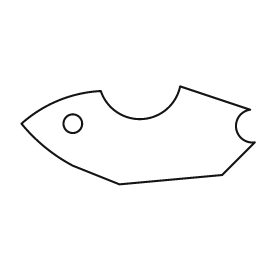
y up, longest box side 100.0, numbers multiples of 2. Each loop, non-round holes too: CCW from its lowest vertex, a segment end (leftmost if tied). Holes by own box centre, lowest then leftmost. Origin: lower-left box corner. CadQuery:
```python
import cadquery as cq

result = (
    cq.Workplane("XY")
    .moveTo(42.0, 0.0)
    .lineTo(86.0, 4.0)
    .lineTo(100.0, 18.0)
    .threePointArc((92.0, 24.0), (98.0, 32.0))
    .lineTo(68.0, 42.0)
    .threePointArc((52.0, 28.0), (34.0, 40.0))
    .threePointArc((16.0, 36.0), (0.0, 26.0))
    .threePointArc((10.0, 16.0), (22.0, 8.0))
    .close()
    .moveTo(22.0, 26.0)
    .circle(4.0)
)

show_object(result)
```